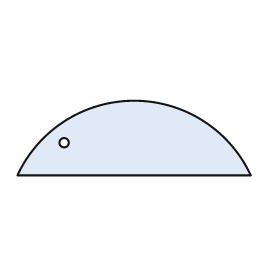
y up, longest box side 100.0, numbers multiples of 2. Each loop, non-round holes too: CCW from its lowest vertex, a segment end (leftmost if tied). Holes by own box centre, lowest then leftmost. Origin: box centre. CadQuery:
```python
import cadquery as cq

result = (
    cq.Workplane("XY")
    .moveTo(-50.0, -16.0)
    .lineTo(50.0, -16.0)
    .threePointArc((0.0, 16.0), (-50.0, -16.0))
    .close()
    .moveTo(-30.0, -2.0)
    .circle(2.0)
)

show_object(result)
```